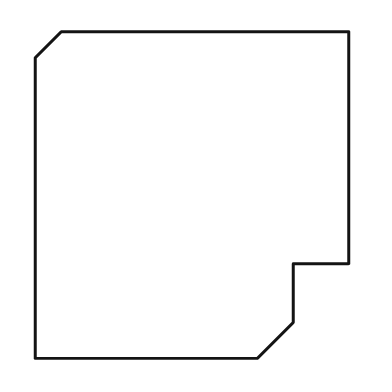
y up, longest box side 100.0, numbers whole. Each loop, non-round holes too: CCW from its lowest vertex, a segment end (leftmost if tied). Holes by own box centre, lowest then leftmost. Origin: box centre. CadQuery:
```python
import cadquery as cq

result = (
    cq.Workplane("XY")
    .moveTo(-48.0, -50.0)
    .lineTo(20.0, -50.0)
    .lineTo(31.0, -39.0)
    .lineTo(31.0, -21.0)
    .lineTo(48.0, -21.0)
    .lineTo(48.0, 50.0)
    .lineTo(-40.0, 50.0)
    .lineTo(-48.0, 42.0)
    .close()
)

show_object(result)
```